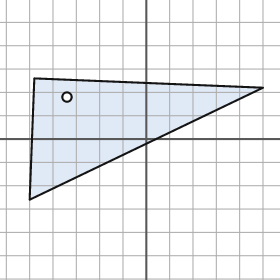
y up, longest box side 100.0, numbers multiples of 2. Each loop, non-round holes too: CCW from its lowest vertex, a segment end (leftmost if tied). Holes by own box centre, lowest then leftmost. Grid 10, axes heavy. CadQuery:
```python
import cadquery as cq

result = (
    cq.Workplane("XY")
    .moveTo(-50.0, -26.0)
    .lineTo(50.0, 22.0)
    .lineTo(-48.0, 26.0)
    .close()
    .moveTo(-34.0, 18.0)
    .circle(2.0)
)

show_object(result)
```